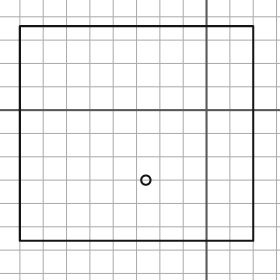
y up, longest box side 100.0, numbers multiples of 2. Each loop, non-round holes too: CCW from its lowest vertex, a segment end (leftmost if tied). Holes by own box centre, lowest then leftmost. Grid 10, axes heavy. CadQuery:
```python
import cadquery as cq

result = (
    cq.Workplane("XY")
    .moveTo(-80.0, -56.0)
    .lineTo(20.0, -56.0)
    .lineTo(20.0, 36.0)
    .lineTo(-80.0, 36.0)
    .close()
    .moveTo(-26.0, -30.0)
    .circle(2.0)
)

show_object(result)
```